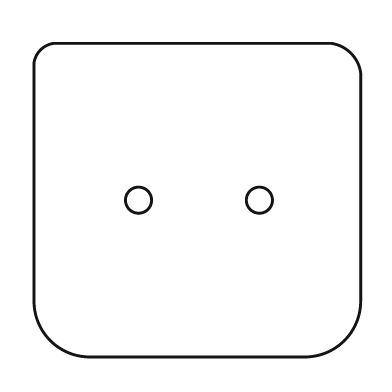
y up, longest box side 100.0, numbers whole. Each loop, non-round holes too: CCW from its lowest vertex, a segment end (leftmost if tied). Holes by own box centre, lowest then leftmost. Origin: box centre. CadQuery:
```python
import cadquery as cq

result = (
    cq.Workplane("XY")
    .moveTo(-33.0, -48.0)
    .lineTo(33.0, -48.0)
    .threePointArc((45.0, -43.0), (50.0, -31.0))
    .lineTo(50.0, 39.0)
    .threePointArc((47.0, 45.0), (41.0, 48.0))
    .lineTo(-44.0, 48.0)
    .threePointArc((-48.0, 46.0), (-50.0, 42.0))
    .lineTo(-50.0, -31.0)
    .threePointArc((-45.0, -43.0), (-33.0, -48.0))
    .close()
    .moveTo(-18.0, 0.0)
    .circle(4.0)
    .moveTo(19.0, 0.0)
    .circle(4.0)
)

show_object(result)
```